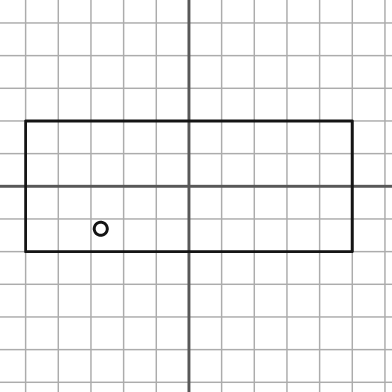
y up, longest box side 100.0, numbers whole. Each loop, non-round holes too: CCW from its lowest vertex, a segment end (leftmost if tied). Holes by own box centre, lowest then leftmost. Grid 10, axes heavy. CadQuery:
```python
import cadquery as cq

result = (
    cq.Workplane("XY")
    .moveTo(-50.0, -20.0)
    .lineTo(50.0, -20.0)
    .lineTo(50.0, 20.0)
    .lineTo(-50.0, 20.0)
    .close()
    .moveTo(-27.0, -13.0)
    .circle(2.0)
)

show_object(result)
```